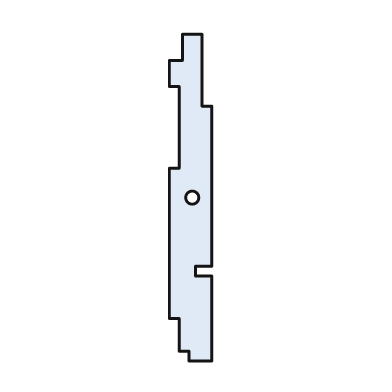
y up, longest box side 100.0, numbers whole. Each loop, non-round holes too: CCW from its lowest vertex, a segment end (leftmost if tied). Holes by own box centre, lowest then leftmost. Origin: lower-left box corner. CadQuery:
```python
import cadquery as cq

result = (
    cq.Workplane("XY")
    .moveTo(6.0, 0.0)
    .lineTo(13.0, 0.0)
    .lineTo(13.0, 26.0)
    .lineTo(8.0, 26.0)
    .lineTo(8.0, 29.0)
    .lineTo(13.0, 29.0)
    .lineTo(13.0, 78.0)
    .lineTo(10.0, 78.0)
    .lineTo(10.0, 100.0)
    .lineTo(4.0, 100.0)
    .lineTo(4.0, 92.0)
    .lineTo(0.0, 92.0)
    .lineTo(0.0, 84.0)
    .lineTo(3.0, 84.0)
    .lineTo(3.0, 59.0)
    .lineTo(0.0, 59.0)
    .lineTo(0.0, 13.0)
    .lineTo(3.0, 13.0)
    .lineTo(3.0, 3.0)
    .lineTo(6.0, 3.0)
    .close()
    .moveTo(7.0, 50.0)
    .circle(2.0)
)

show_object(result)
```